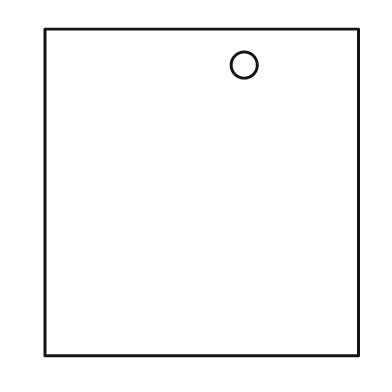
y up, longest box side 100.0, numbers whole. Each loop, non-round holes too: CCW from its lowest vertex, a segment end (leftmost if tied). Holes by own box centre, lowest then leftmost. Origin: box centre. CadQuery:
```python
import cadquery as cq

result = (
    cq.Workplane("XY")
    .moveTo(-48.0, -50.0)
    .lineTo(48.0, -50.0)
    .lineTo(48.0, 50.0)
    .lineTo(-48.0, 50.0)
    .close()
    .moveTo(13.0, 39.0)
    .circle(4.0)
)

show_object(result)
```